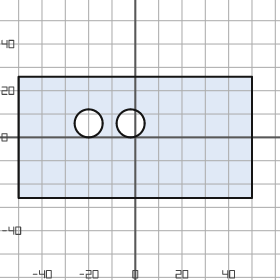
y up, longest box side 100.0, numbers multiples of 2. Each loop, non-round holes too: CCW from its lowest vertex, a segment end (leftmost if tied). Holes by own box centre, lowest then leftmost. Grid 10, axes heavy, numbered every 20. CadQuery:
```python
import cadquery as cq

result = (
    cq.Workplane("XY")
    .moveTo(-50.0, -26.0)
    .lineTo(50.0, -26.0)
    .lineTo(50.0, 26.0)
    .lineTo(-50.0, 26.0)
    .close()
    .moveTo(-20.0, 6.0)
    .circle(6.0)
    .moveTo(-2.0, 6.0)
    .circle(6.0)
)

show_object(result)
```